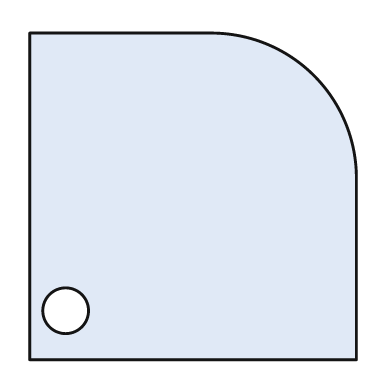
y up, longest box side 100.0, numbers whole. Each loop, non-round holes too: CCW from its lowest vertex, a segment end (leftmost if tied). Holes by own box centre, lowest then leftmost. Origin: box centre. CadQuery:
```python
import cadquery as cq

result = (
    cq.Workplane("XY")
    .moveTo(-50.0, -50.0)
    .lineTo(50.0, -50.0)
    .lineTo(50.0, 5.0)
    .threePointArc((37.0, 37.0), (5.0, 50.0))
    .lineTo(-50.0, 50.0)
    .close()
    .moveTo(-39.0, -35.0)
    .circle(7.0)
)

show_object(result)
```